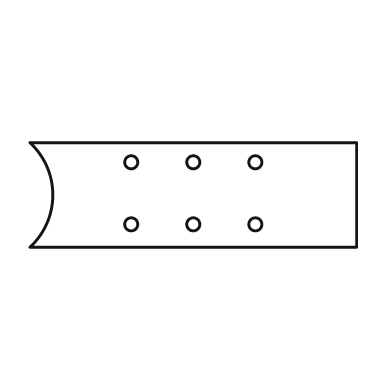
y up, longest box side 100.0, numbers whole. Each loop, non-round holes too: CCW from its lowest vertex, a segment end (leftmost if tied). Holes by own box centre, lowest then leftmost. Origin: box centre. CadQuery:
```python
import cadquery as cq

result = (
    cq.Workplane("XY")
    .moveTo(-50.0, -16.0)
    .lineTo(50.0, -16.0)
    .lineTo(50.0, 16.0)
    .lineTo(-50.0, 16.0)
    .threePointArc((-43.0, 0.0), (-50.0, -16.0))
    .close()
    .moveTo(-19.0, -9.0)
    .circle(2.0)
    .moveTo(0.0, -9.0)
    .circle(2.0)
    .moveTo(19.0, -9.0)
    .circle(2.0)
    .moveTo(-19.0, 10.0)
    .circle(2.0)
    .moveTo(0.0, 10.0)
    .circle(2.0)
    .moveTo(19.0, 10.0)
    .circle(2.0)
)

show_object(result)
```